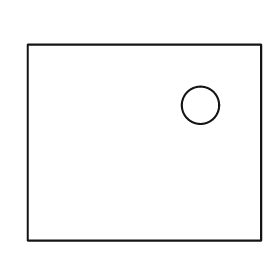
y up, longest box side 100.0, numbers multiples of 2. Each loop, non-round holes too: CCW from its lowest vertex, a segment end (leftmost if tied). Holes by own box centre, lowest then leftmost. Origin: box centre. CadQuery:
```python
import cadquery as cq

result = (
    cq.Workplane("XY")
    .moveTo(-50.0, -42.0)
    .lineTo(50.0, -42.0)
    .lineTo(50.0, 42.0)
    .lineTo(-50.0, 42.0)
    .close()
    .moveTo(24.0, 16.0)
    .circle(8.0)
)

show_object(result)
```